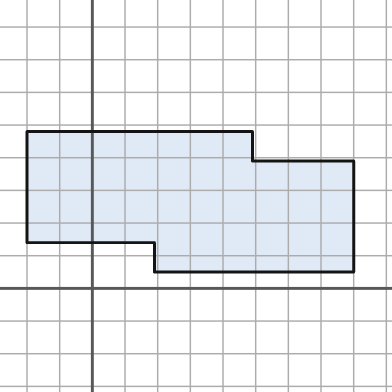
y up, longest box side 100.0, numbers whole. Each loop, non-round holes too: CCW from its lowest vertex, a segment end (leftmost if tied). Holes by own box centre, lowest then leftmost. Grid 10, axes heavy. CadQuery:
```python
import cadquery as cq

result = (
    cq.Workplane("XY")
    .moveTo(19.0, 5.0)
    .lineTo(80.0, 5.0)
    .lineTo(80.0, 39.0)
    .lineTo(49.0, 39.0)
    .lineTo(49.0, 48.0)
    .lineTo(-20.0, 48.0)
    .lineTo(-20.0, 14.0)
    .lineTo(19.0, 14.0)
    .close()
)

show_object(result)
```